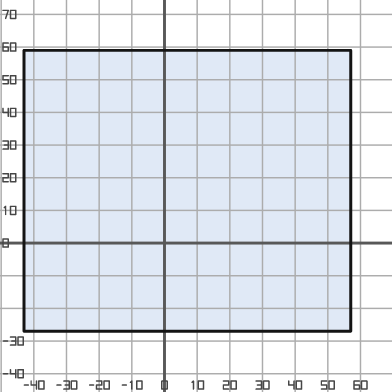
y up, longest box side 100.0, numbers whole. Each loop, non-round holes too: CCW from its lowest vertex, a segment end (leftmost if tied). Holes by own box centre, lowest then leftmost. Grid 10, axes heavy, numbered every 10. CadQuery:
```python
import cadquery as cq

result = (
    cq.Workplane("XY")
    .moveTo(-43.0, -27.0)
    .lineTo(57.0, -27.0)
    .lineTo(57.0, 59.0)
    .lineTo(-43.0, 59.0)
    .close()
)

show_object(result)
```